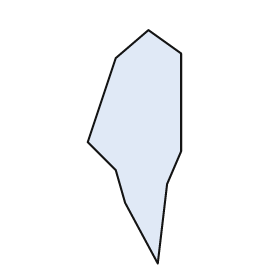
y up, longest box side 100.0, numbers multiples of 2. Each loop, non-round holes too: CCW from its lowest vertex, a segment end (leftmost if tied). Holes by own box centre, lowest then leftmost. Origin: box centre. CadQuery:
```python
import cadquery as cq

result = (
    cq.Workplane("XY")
    .moveTo(10.0, -50.0)
    .lineTo(14.0, -16.0)
    .lineTo(20.0, -2.0)
    .lineTo(20.0, 40.0)
    .lineTo(6.0, 50.0)
    .lineTo(-8.0, 38.0)
    .lineTo(-20.0, 2.0)
    .lineTo(-8.0, -10.0)
    .lineTo(-4.0, -24.0)
    .close()
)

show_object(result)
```